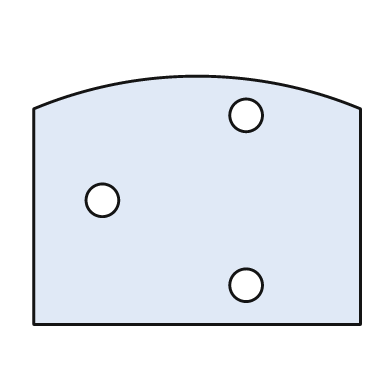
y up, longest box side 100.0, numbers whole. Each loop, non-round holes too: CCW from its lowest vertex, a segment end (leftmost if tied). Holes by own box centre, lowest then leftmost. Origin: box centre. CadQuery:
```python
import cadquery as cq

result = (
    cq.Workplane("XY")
    .moveTo(-50.0, -38.0)
    .lineTo(50.0, -38.0)
    .lineTo(50.0, 28.0)
    .threePointArc((0.0, 38.0), (-50.0, 28.0))
    .close()
    .moveTo(15.0, -26.0)
    .circle(5.0)
    .moveTo(-29.0, 0.0)
    .circle(5.0)
    .moveTo(15.0, 26.0)
    .circle(5.0)
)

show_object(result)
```